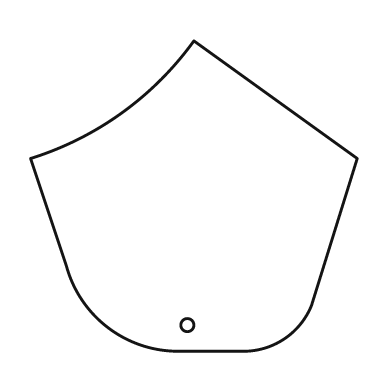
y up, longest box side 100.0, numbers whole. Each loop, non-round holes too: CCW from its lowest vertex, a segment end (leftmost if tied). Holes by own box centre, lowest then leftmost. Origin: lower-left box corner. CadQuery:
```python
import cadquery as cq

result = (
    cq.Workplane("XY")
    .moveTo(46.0, 0.0)
    .lineTo(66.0, 0.0)
    .threePointArc((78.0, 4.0), (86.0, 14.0))
    .lineTo(100.0, 59.0)
    .lineTo(50.0, 95.0)
    .threePointArc((28.0, 73.0), (0.0, 59.0))
    .lineTo(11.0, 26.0)
    .threePointArc((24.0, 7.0), (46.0, 0.0))
    .close()
    .moveTo(48.0, 8.0)
    .circle(2.0)
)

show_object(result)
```